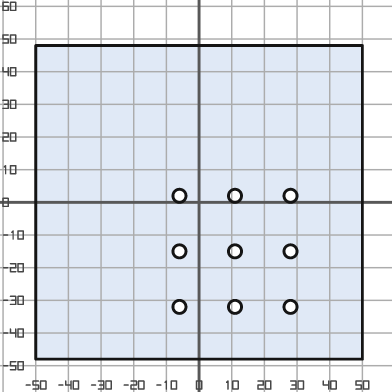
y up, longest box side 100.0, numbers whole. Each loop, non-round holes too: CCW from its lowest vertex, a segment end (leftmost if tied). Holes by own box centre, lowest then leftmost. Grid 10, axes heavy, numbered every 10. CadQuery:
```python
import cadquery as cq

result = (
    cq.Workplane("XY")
    .moveTo(-50.0, -48.0)
    .lineTo(50.0, -48.0)
    .lineTo(50.0, 48.0)
    .lineTo(-50.0, 48.0)
    .close()
    .moveTo(-6.0, -32.0)
    .circle(2.0)
    .moveTo(11.0, -32.0)
    .circle(2.0)
    .moveTo(28.0, -32.0)
    .circle(2.0)
    .moveTo(-6.0, -15.0)
    .circle(2.0)
    .moveTo(11.0, -15.0)
    .circle(2.0)
    .moveTo(28.0, -15.0)
    .circle(2.0)
    .moveTo(-6.0, 2.0)
    .circle(2.0)
    .moveTo(11.0, 2.0)
    .circle(2.0)
    .moveTo(28.0, 2.0)
    .circle(2.0)
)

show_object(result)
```